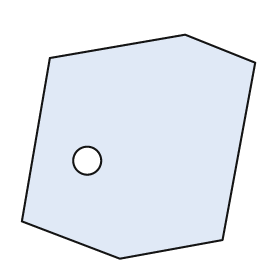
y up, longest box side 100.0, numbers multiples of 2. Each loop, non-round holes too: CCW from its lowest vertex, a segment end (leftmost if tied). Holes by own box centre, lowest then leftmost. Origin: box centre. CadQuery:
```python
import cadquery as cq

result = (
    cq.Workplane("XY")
    .moveTo(-8.0, -48.0)
    .lineTo(36.0, -40.0)
    .lineTo(50.0, 36.0)
    .lineTo(20.0, 48.0)
    .lineTo(-38.0, 38.0)
    .lineTo(-50.0, -32.0)
    .close()
    .moveTo(-22.0, -6.0)
    .circle(6.0)
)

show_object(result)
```